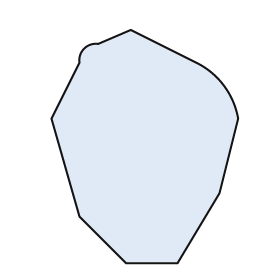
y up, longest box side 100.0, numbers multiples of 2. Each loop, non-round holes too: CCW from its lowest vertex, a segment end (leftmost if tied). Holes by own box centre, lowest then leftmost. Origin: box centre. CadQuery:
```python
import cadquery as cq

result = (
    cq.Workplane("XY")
    .moveTo(-8.0, -50.0)
    .lineTo(14.0, -50.0)
    .lineTo(32.0, -20.0)
    .lineTo(40.0, 12.0)
    .threePointArc((34.0, 26.0), (22.0, 36.0))
    .lineTo(-6.0, 50.0)
    .lineTo(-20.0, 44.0)
    .threePointArc((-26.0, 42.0), (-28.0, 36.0))
    .lineTo(-40.0, 12.0)
    .lineTo(-28.0, -30.0)
    .close()
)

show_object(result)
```